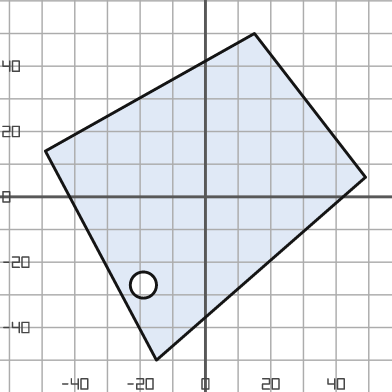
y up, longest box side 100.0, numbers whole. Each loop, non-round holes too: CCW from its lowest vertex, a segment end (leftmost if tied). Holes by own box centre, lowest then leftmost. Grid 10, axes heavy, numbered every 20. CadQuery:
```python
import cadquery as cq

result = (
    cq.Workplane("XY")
    .moveTo(-15.0, -50.0)
    .lineTo(49.0, 6.0)
    .lineTo(15.0, 50.0)
    .lineTo(-49.0, 14.0)
    .close()
    .moveTo(-19.0, -27.0)
    .circle(4.0)
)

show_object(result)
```